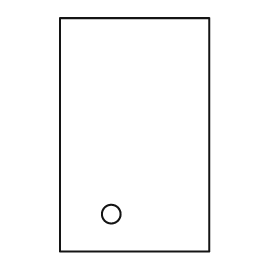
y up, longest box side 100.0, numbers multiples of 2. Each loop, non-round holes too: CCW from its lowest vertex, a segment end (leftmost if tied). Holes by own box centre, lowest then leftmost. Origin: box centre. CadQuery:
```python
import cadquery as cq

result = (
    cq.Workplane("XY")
    .moveTo(-32.0, -50.0)
    .lineTo(32.0, -50.0)
    .lineTo(32.0, 50.0)
    .lineTo(-32.0, 50.0)
    .close()
    .moveTo(-10.0, -34.0)
    .circle(4.0)
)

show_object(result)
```